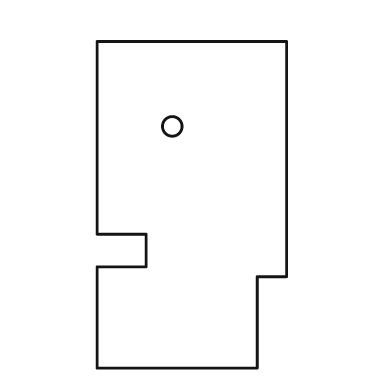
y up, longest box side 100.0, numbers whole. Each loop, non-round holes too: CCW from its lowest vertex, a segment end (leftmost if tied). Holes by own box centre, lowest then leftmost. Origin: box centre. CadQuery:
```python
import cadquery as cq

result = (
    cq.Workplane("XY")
    .moveTo(-29.0, -50.0)
    .lineTo(20.0, -50.0)
    .lineTo(20.0, -22.0)
    .lineTo(29.0, -22.0)
    .lineTo(29.0, 50.0)
    .lineTo(-29.0, 50.0)
    .lineTo(-29.0, -9.0)
    .lineTo(-14.0, -9.0)
    .lineTo(-14.0, -19.0)
    .lineTo(-29.0, -19.0)
    .close()
    .moveTo(-6.0, 24.0)
    .circle(3.0)
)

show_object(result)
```